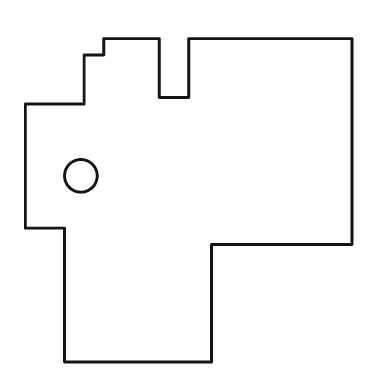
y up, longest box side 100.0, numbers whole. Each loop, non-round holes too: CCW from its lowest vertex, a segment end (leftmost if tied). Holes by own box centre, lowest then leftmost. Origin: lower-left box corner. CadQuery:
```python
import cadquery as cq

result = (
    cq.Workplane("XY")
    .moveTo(12.0, 0.0)
    .lineTo(57.0, 0.0)
    .lineTo(57.0, 36.0)
    .lineTo(100.0, 36.0)
    .lineTo(100.0, 99.0)
    .lineTo(50.0, 99.0)
    .lineTo(50.0, 81.0)
    .lineTo(41.0, 81.0)
    .lineTo(41.0, 99.0)
    .lineTo(24.0, 99.0)
    .lineTo(24.0, 94.0)
    .lineTo(18.0, 94.0)
    .lineTo(18.0, 79.0)
    .lineTo(0.0, 79.0)
    .lineTo(0.0, 41.0)
    .lineTo(12.0, 41.0)
    .close()
    .moveTo(17.0, 57.0)
    .circle(5.0)
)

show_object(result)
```